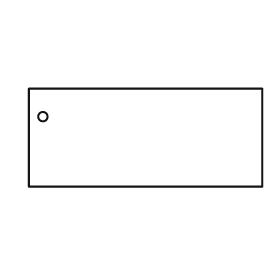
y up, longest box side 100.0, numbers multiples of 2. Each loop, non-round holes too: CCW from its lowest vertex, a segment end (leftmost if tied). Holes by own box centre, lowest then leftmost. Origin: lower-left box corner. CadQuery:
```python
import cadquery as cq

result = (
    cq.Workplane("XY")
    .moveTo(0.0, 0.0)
    .lineTo(100.0, 0.0)
    .lineTo(100.0, 42.0)
    .lineTo(0.0, 42.0)
    .close()
    .moveTo(6.0, 30.0)
    .circle(2.0)
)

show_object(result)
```